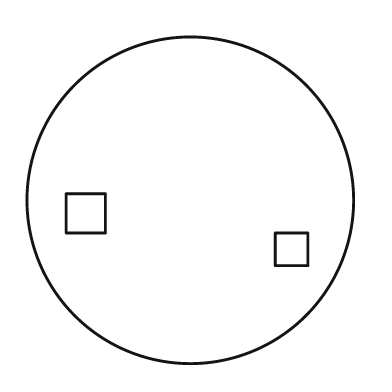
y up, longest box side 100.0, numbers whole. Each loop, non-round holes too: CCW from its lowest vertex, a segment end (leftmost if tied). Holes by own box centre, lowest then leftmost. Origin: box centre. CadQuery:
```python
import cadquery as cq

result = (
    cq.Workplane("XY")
    .moveTo(0.0, 0.0)
    .circle(50.0)
    .moveTo(26.0, -20.0)
    .lineTo(36.0, -20.0)
    .lineTo(36.0, -10.0)
    .lineTo(26.0, -10.0)
    .close()
    .moveTo(-38.0, -10.0)
    .lineTo(-26.0, -10.0)
    .lineTo(-26.0, 2.0)
    .lineTo(-38.0, 2.0)
    .close()
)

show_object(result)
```